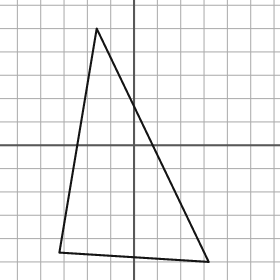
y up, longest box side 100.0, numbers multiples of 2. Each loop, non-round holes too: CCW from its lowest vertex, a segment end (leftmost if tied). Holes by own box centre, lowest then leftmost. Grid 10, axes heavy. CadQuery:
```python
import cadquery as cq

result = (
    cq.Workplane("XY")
    .moveTo(32.0, -50.0)
    .lineTo(-16.0, 50.0)
    .lineTo(-32.0, -46.0)
    .close()
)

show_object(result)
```